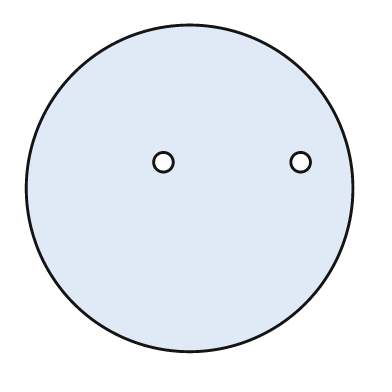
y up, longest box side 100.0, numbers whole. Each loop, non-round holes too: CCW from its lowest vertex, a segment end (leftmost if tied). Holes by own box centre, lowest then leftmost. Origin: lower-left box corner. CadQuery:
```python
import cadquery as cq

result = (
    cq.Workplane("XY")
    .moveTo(50.0, 50.0)
    .circle(50.0)
    .moveTo(42.0, 58.0)
    .circle(3.0)
    .moveTo(84.0, 58.0)
    .circle(3.0)
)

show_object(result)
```